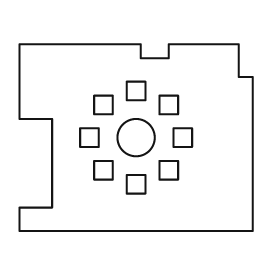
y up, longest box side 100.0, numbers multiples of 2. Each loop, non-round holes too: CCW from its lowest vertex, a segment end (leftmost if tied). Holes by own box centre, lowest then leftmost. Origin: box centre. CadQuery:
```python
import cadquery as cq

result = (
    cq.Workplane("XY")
    .moveTo(-50.0, -40.0)
    .lineTo(50.0, -40.0)
    .lineTo(50.0, 26.0)
    .lineTo(44.0, 26.0)
    .lineTo(44.0, 40.0)
    .lineTo(14.0, 40.0)
    .lineTo(14.0, 34.0)
    .lineTo(2.0, 34.0)
    .lineTo(2.0, 40.0)
    .lineTo(-50.0, 40.0)
    .lineTo(-50.0, 8.0)
    .lineTo(-36.0, 8.0)
    .lineTo(-36.0, -30.0)
    .lineTo(-50.0, -30.0)
    .close()
    .moveTo(-4.0, -24.0)
    .lineTo(4.0, -24.0)
    .lineTo(4.0, -16.0)
    .lineTo(-4.0, -16.0)
    .close()
    .moveTo(-18.0, -18.0)
    .lineTo(-10.0, -18.0)
    .lineTo(-10.0, -10.0)
    .lineTo(-18.0, -10.0)
    .close()
    .moveTo(10.0, -18.0)
    .lineTo(18.0, -18.0)
    .lineTo(18.0, -10.0)
    .lineTo(10.0, -10.0)
    .close()
    .moveTo(-24.0, -4.0)
    .lineTo(-16.0, -4.0)
    .lineTo(-16.0, 4.0)
    .lineTo(-24.0, 4.0)
    .close()
    .moveTo(0.0, 0.0)
    .circle(8.0)
    .moveTo(16.0, -4.0)
    .lineTo(24.0, -4.0)
    .lineTo(24.0, 4.0)
    .lineTo(16.0, 4.0)
    .close()
    .moveTo(-18.0, 10.0)
    .lineTo(-10.0, 10.0)
    .lineTo(-10.0, 18.0)
    .lineTo(-18.0, 18.0)
    .close()
    .moveTo(10.0, 10.0)
    .lineTo(18.0, 10.0)
    .lineTo(18.0, 18.0)
    .lineTo(10.0, 18.0)
    .close()
    .moveTo(-4.0, 16.0)
    .lineTo(4.0, 16.0)
    .lineTo(4.0, 24.0)
    .lineTo(-4.0, 24.0)
    .close()
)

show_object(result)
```